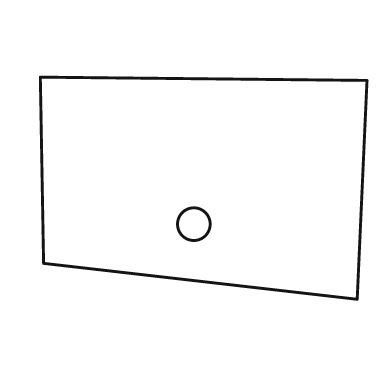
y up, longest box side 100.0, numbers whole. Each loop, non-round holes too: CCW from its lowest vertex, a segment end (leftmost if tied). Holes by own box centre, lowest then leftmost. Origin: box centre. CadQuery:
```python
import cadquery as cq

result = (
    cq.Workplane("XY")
    .moveTo(47.0, -34.0)
    .lineTo(50.0, 33.0)
    .lineTo(-50.0, 34.0)
    .lineTo(-49.0, -23.0)
    .close()
    .moveTo(-3.0, -11.0)
    .circle(5.0)
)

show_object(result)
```